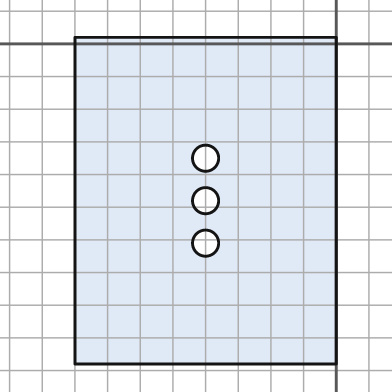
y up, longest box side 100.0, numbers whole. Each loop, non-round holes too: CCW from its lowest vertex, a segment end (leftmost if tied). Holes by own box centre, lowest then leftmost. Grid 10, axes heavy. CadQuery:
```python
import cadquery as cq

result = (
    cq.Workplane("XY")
    .moveTo(-80.0, -98.0)
    .lineTo(0.0, -98.0)
    .lineTo(0.0, 2.0)
    .lineTo(-80.0, 2.0)
    .close()
    .moveTo(-40.0, -61.0)
    .circle(4.0)
    .moveTo(-40.0, -48.0)
    .circle(4.0)
    .moveTo(-40.0, -35.0)
    .circle(4.0)
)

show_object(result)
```